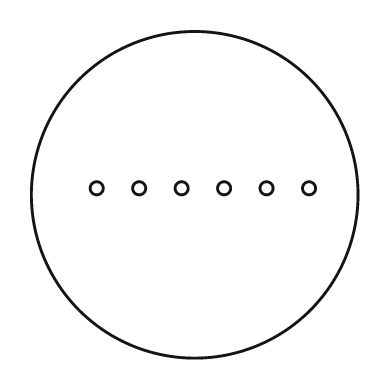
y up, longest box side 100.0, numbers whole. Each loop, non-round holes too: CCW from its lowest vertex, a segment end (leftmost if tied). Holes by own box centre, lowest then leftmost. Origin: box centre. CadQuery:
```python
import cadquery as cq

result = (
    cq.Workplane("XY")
    .moveTo(0.0, 0.0)
    .circle(50.0)
    .moveTo(-30.0, 2.0)
    .circle(2.0)
    .moveTo(-17.0, 2.0)
    .circle(2.0)
    .moveTo(-4.0, 2.0)
    .circle(2.0)
    .moveTo(9.0, 2.0)
    .circle(2.0)
    .moveTo(22.0, 2.0)
    .circle(2.0)
    .moveTo(35.0, 2.0)
    .circle(2.0)
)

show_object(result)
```